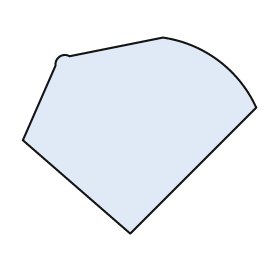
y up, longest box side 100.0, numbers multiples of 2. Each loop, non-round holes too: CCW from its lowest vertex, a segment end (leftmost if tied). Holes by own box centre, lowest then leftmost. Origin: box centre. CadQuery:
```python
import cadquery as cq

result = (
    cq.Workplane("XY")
    .moveTo(-4.0, -42.0)
    .lineTo(50.0, 12.0)
    .threePointArc((34.0, 32.0), (10.0, 42.0))
    .lineTo(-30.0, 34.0)
    .threePointArc((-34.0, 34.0), (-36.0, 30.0))
    .lineTo(-50.0, -2.0)
    .close()
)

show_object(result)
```